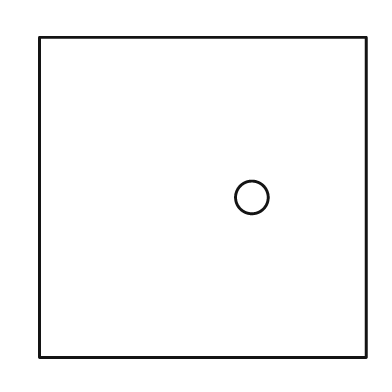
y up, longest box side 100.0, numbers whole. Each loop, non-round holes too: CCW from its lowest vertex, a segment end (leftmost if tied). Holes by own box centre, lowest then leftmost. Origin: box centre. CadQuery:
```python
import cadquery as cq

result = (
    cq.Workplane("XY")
    .moveTo(-50.0, -49.0)
    .lineTo(50.0, -49.0)
    .lineTo(50.0, 49.0)
    .lineTo(-50.0, 49.0)
    .close()
    .moveTo(15.0, 0.0)
    .circle(5.0)
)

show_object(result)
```